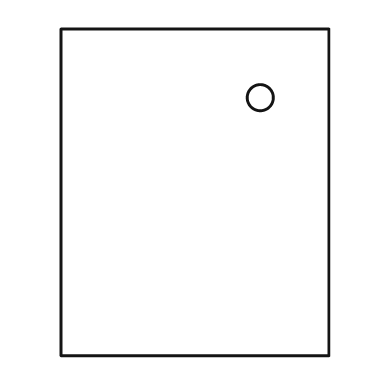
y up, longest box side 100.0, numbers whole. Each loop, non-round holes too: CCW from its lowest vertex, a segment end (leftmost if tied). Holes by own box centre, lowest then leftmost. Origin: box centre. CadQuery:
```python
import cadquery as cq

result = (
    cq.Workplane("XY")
    .moveTo(-41.0, -50.0)
    .lineTo(41.0, -50.0)
    .lineTo(41.0, 50.0)
    .lineTo(-41.0, 50.0)
    .close()
    .moveTo(20.0, 29.0)
    .circle(4.0)
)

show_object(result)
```